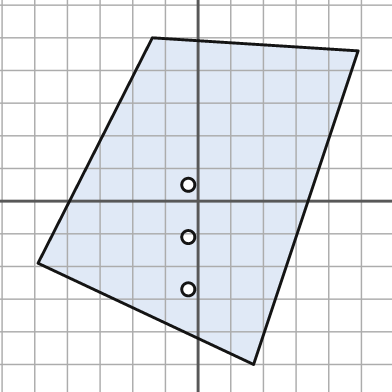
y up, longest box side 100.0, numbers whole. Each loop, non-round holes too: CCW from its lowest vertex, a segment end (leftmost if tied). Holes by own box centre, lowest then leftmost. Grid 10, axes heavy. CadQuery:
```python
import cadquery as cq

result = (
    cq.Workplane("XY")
    .moveTo(17.0, -50.0)
    .lineTo(49.0, 46.0)
    .lineTo(-14.0, 50.0)
    .lineTo(-49.0, -19.0)
    .close()
    .moveTo(-3.0, -27.0)
    .circle(2.0)
    .moveTo(-3.0, -11.0)
    .circle(2.0)
    .moveTo(-3.0, 5.0)
    .circle(2.0)
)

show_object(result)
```